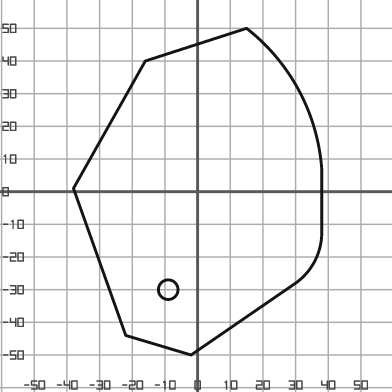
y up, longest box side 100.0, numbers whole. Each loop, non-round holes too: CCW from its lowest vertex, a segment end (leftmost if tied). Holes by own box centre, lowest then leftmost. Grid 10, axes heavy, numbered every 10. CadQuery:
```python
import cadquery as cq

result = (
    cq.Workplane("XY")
    .moveTo(-2.0, -50.0)
    .lineTo(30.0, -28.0)
    .threePointArc((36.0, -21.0), (38.0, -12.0))
    .lineTo(38.0, 7.0)
    .threePointArc((31.0, 31.0), (15.0, 50.0))
    .lineTo(-16.0, 40.0)
    .lineTo(-38.0, 1.0)
    .lineTo(-22.0, -44.0)
    .close()
    .moveTo(-9.0, -30.0)
    .circle(3.0)
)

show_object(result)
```